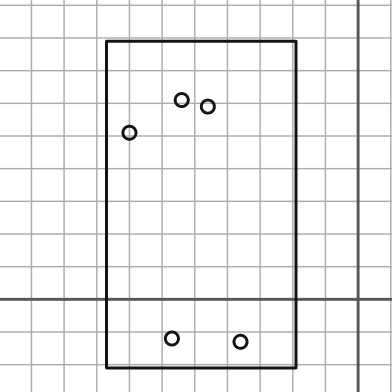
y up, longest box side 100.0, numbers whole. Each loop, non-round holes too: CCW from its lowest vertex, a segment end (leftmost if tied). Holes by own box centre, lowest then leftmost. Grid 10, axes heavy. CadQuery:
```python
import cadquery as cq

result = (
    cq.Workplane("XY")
    .moveTo(-77.0, -21.0)
    .lineTo(-19.0, -21.0)
    .lineTo(-19.0, 79.0)
    .lineTo(-77.0, 79.0)
    .close()
    .moveTo(-36.0, -13.0)
    .circle(2.0)
    .moveTo(-57.0, -12.0)
    .circle(2.0)
    .moveTo(-70.0, 51.0)
    .circle(2.0)
    .moveTo(-46.0, 59.0)
    .circle(2.0)
    .moveTo(-54.0, 61.0)
    .circle(2.0)
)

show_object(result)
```